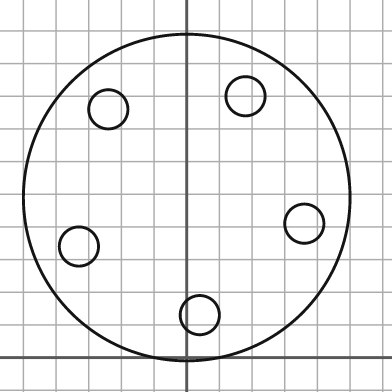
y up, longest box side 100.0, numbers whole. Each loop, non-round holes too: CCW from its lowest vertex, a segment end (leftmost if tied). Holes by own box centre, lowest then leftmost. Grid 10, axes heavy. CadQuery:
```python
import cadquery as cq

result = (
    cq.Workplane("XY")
    .moveTo(0.0, 49.0)
    .circle(50.0)
    .moveTo(4.0, 13.0)
    .circle(6.0)
    .moveTo(-33.0, 34.0)
    .circle(6.0)
    .moveTo(36.0, 41.0)
    .circle(6.0)
    .moveTo(-24.0, 76.0)
    .circle(6.0)
    .moveTo(18.0, 80.0)
    .circle(6.0)
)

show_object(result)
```